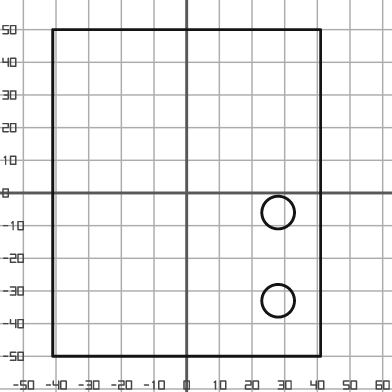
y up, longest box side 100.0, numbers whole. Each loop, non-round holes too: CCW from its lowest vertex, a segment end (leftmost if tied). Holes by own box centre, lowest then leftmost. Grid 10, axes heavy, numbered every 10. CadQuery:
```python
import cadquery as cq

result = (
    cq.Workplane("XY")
    .moveTo(-41.0, -50.0)
    .lineTo(41.0, -50.0)
    .lineTo(41.0, 50.0)
    .lineTo(-41.0, 50.0)
    .close()
    .moveTo(28.0, -33.0)
    .circle(5.0)
    .moveTo(28.0, -6.0)
    .circle(5.0)
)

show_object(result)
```